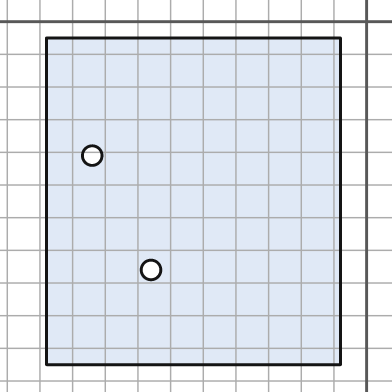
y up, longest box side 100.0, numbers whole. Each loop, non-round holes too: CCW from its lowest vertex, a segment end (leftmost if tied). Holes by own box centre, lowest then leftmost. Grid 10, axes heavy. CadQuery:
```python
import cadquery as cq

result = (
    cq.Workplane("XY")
    .moveTo(-98.0, -105.0)
    .lineTo(-8.0, -105.0)
    .lineTo(-8.0, -5.0)
    .lineTo(-98.0, -5.0)
    .close()
    .moveTo(-66.0, -76.0)
    .circle(3.0)
    .moveTo(-84.0, -41.0)
    .circle(3.0)
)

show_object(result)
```